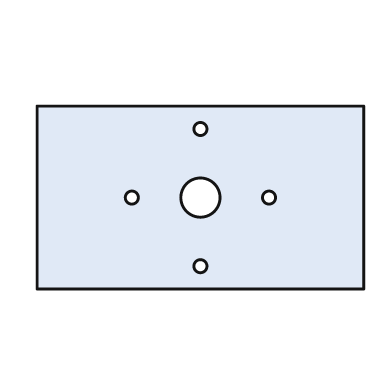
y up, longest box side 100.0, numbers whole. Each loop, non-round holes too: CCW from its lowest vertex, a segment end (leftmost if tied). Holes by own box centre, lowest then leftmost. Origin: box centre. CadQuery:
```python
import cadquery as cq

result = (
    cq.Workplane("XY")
    .moveTo(-50.0, -28.0)
    .lineTo(50.0, -28.0)
    .lineTo(50.0, 28.0)
    .lineTo(-50.0, 28.0)
    .close()
    .moveTo(0.0, -21.0)
    .circle(2.0)
    .moveTo(-21.0, 0.0)
    .circle(2.0)
    .moveTo(0.0, 0.0)
    .circle(6.0)
    .moveTo(21.0, 0.0)
    .circle(2.0)
    .moveTo(0.0, 21.0)
    .circle(2.0)
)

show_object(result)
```